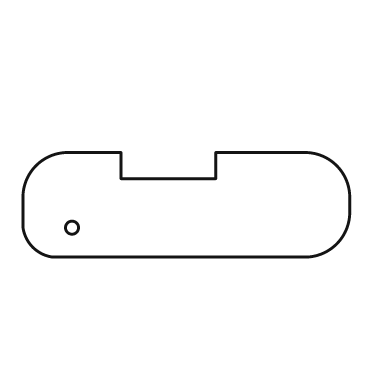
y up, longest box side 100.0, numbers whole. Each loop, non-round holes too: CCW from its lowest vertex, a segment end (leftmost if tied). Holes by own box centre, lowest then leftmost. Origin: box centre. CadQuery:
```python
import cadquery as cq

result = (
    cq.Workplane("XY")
    .moveTo(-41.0, -16.0)
    .lineTo(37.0, -16.0)
    .threePointArc((46.0, -12.0), (50.0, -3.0))
    .lineTo(50.0, 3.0)
    .threePointArc((46.0, 12.0), (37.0, 16.0))
    .lineTo(9.0, 16.0)
    .lineTo(9.0, 8.0)
    .lineTo(-20.0, 8.0)
    .lineTo(-20.0, 16.0)
    .lineTo(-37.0, 16.0)
    .threePointArc((-46.0, 12.0), (-50.0, 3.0))
    .lineTo(-50.0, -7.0)
    .threePointArc((-47.0, -13.0), (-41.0, -16.0))
    .close()
    .moveTo(-35.0, -7.0)
    .circle(2.0)
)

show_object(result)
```